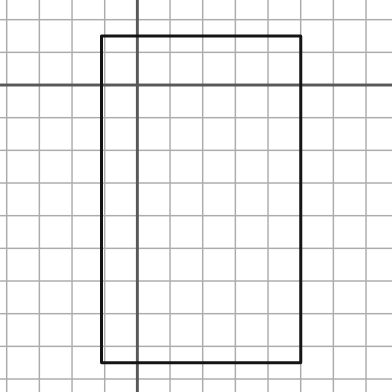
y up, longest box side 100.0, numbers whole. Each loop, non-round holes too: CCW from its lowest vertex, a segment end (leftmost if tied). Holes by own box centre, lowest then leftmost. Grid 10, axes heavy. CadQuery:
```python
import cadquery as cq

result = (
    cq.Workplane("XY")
    .moveTo(-11.0, -85.0)
    .lineTo(50.0, -85.0)
    .lineTo(50.0, 15.0)
    .lineTo(-11.0, 15.0)
    .close()
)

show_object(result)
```